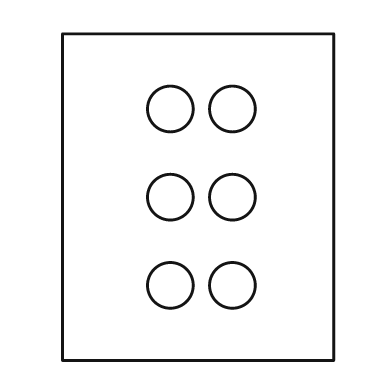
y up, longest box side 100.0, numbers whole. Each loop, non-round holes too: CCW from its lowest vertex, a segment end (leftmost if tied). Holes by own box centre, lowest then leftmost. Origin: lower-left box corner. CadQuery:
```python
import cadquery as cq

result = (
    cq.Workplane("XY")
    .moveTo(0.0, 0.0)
    .lineTo(83.0, 0.0)
    .lineTo(83.0, 100.0)
    .lineTo(0.0, 100.0)
    .close()
    .moveTo(33.0, 23.0)
    .circle(7.0)
    .moveTo(52.0, 23.0)
    .circle(7.0)
    .moveTo(33.0, 50.0)
    .circle(7.0)
    .moveTo(52.0, 50.0)
    .circle(7.0)
    .moveTo(33.0, 77.0)
    .circle(7.0)
    .moveTo(52.0, 77.0)
    .circle(7.0)
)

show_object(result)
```